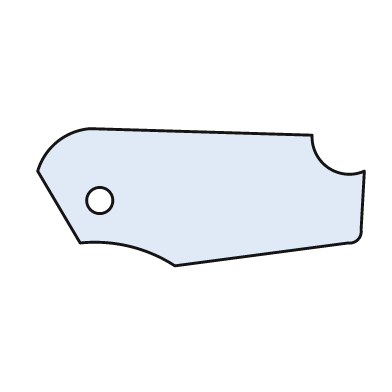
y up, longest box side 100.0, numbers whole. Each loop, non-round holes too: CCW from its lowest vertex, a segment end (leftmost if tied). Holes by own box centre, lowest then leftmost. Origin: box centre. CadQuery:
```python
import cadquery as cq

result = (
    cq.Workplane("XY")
    .moveTo(-8.0, -21.0)
    .lineTo(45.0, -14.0)
    .threePointArc((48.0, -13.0), (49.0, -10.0))
    .lineTo(50.0, 8.0)
    .threePointArc((39.0, 9.0), (34.0, 19.0))
    .lineTo(-34.0, 21.0)
    .threePointArc((-44.0, 17.0), (-50.0, 8.0))
    .lineTo(-37.0, -14.0)
    .threePointArc((-22.0, -15.0), (-8.0, -21.0))
    .close()
    .moveTo(-31.0, -1.0)
    .circle(4.0)
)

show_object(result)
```